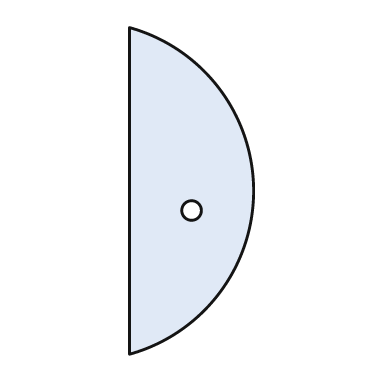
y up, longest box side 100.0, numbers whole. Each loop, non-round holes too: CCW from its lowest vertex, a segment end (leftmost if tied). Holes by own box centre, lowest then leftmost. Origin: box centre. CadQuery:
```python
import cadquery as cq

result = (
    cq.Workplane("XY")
    .moveTo(-19.0, -50.0)
    .threePointArc((19.0, 0.0), (-19.0, 50.0))
    .close()
    .moveTo(0.0, -6.0)
    .circle(3.0)
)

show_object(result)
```